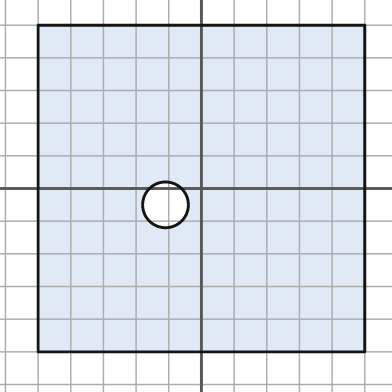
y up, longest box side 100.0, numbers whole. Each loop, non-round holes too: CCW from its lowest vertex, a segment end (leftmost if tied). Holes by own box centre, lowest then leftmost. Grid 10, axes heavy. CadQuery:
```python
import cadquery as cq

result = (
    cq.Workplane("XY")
    .moveTo(-50.0, -50.0)
    .lineTo(50.0, -50.0)
    .lineTo(50.0, 50.0)
    .lineTo(-50.0, 50.0)
    .close()
    .moveTo(-11.0, -5.0)
    .circle(7.0)
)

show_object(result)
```